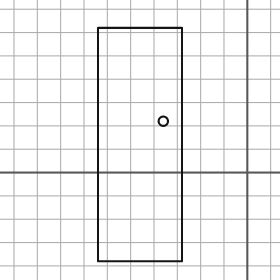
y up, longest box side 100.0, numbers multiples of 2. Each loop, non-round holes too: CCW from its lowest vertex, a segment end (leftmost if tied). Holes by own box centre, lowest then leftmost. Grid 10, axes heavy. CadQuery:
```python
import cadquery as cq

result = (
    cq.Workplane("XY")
    .moveTo(-64.0, -38.0)
    .lineTo(-28.0, -38.0)
    .lineTo(-28.0, 62.0)
    .lineTo(-64.0, 62.0)
    .close()
    .moveTo(-36.0, 22.0)
    .circle(2.0)
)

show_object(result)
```